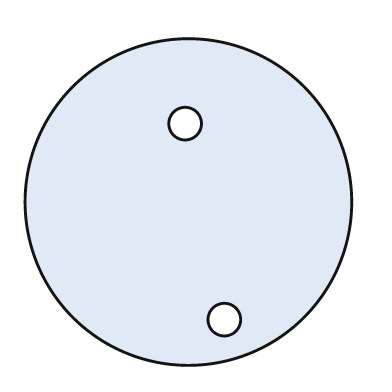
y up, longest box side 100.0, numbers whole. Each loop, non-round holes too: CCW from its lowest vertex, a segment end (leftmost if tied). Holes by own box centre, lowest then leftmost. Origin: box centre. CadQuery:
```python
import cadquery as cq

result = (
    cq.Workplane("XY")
    .moveTo(0.0, 0.0)
    .circle(50.0)
    .moveTo(11.0, -36.0)
    .circle(5.0)
    .moveTo(-1.0, 24.0)
    .circle(5.0)
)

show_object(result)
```